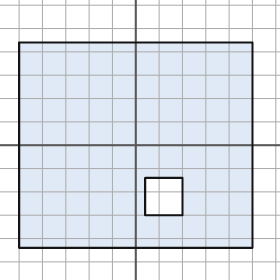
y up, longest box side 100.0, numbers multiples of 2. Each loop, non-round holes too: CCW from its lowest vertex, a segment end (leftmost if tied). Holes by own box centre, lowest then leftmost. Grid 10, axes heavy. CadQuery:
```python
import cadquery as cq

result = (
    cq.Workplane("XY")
    .moveTo(-50.0, -44.0)
    .lineTo(50.0, -44.0)
    .lineTo(50.0, 44.0)
    .lineTo(-50.0, 44.0)
    .close()
    .moveTo(4.0, -30.0)
    .lineTo(20.0, -30.0)
    .lineTo(20.0, -14.0)
    .lineTo(4.0, -14.0)
    .close()
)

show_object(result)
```